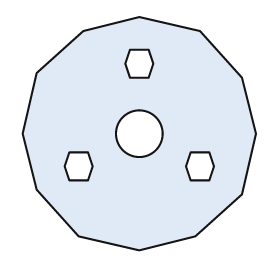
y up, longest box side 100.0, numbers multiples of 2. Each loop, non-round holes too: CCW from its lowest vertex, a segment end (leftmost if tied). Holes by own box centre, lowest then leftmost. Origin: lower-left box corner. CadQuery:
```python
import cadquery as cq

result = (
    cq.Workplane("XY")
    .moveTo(50.0, 0.0)
    .lineTo(74.0, 6.0)
    .lineTo(94.0, 24.0)
    .lineTo(100.0, 50.0)
    .lineTo(94.0, 74.0)
    .lineTo(76.0, 94.0)
    .lineTo(50.0, 100.0)
    .lineTo(26.0, 94.0)
    .lineTo(6.0, 76.0)
    .lineTo(0.0, 50.0)
    .lineTo(6.0, 26.0)
    .lineTo(24.0, 6.0)
    .close()
    .moveTo(20.0, 30.0)
    .lineTo(28.0, 30.0)
    .lineTo(30.0, 36.0)
    .lineTo(28.0, 42.0)
    .lineTo(20.0, 42.0)
    .lineTo(18.0, 36.0)
    .close()
    .moveTo(72.0, 30.0)
    .lineTo(80.0, 30.0)
    .lineTo(82.0, 36.0)
    .lineTo(80.0, 42.0)
    .lineTo(72.0, 42.0)
    .lineTo(70.0, 36.0)
    .close()
    .moveTo(50.0, 50.0)
    .circle(10.0)
    .moveTo(46.0, 74.0)
    .lineTo(54.0, 74.0)
    .lineTo(56.0, 80.0)
    .lineTo(54.0, 86.0)
    .lineTo(46.0, 86.0)
    .lineTo(44.0, 80.0)
    .close()
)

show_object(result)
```